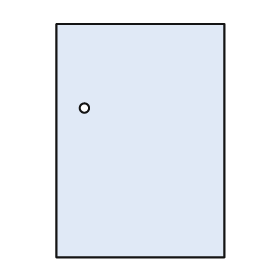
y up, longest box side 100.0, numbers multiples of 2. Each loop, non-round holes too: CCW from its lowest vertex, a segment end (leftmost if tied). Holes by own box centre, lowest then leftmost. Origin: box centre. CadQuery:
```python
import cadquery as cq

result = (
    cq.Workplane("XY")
    .moveTo(-36.0, -50.0)
    .lineTo(36.0, -50.0)
    .lineTo(36.0, 50.0)
    .lineTo(-36.0, 50.0)
    .close()
    .moveTo(-24.0, 14.0)
    .circle(2.0)
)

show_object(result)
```